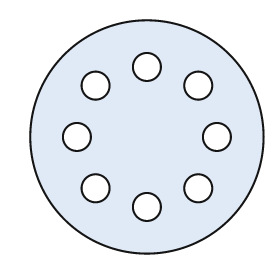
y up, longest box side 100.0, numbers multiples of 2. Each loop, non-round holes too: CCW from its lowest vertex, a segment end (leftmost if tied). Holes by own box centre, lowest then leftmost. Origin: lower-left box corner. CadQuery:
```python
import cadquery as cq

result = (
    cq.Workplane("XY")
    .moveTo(50.0, 50.0)
    .circle(50.0)
    .moveTo(50.0, 20.0)
    .circle(6.0)
    .moveTo(28.0, 28.0)
    .circle(6.0)
    .moveTo(72.0, 28.0)
    .circle(6.0)
    .moveTo(20.0, 50.0)
    .circle(6.0)
    .moveTo(80.0, 50.0)
    .circle(6.0)
    .moveTo(28.0, 72.0)
    .circle(6.0)
    .moveTo(72.0, 72.0)
    .circle(6.0)
    .moveTo(50.0, 80.0)
    .circle(6.0)
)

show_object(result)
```